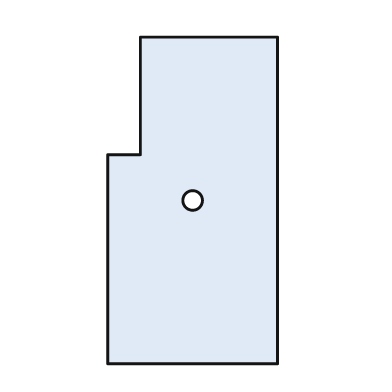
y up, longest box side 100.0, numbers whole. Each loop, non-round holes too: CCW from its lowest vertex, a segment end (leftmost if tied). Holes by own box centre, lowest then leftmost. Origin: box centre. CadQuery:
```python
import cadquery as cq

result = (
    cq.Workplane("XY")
    .moveTo(-26.0, -50.0)
    .lineTo(26.0, -50.0)
    .lineTo(26.0, 50.0)
    .lineTo(-16.0, 50.0)
    .lineTo(-16.0, 14.0)
    .lineTo(-26.0, 14.0)
    .close()
    .moveTo(0.0, 0.0)
    .circle(3.0)
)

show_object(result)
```